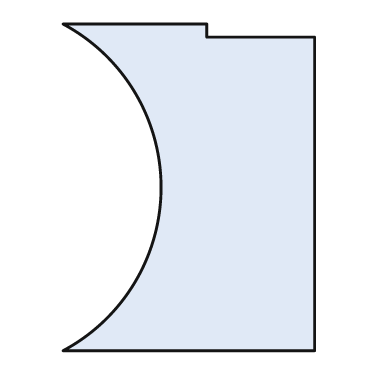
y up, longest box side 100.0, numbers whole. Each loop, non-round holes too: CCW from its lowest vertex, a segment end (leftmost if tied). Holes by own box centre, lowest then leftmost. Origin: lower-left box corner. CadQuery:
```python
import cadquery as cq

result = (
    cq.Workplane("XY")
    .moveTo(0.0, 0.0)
    .lineTo(77.0, 0.0)
    .lineTo(77.0, 96.0)
    .lineTo(44.0, 96.0)
    .lineTo(44.0, 100.0)
    .lineTo(0.0, 100.0)
    .threePointArc((30.0, 50.0), (0.0, 0.0))
    .close()
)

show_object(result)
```